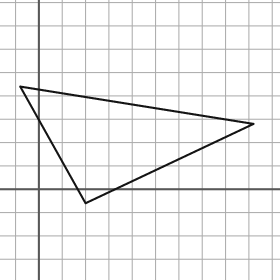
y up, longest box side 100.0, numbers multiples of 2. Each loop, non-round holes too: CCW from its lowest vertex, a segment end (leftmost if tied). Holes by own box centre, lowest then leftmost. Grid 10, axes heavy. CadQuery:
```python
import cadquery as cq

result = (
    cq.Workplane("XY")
    .moveTo(20.0, -6.0)
    .lineTo(92.0, 28.0)
    .lineTo(-8.0, 44.0)
    .close()
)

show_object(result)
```